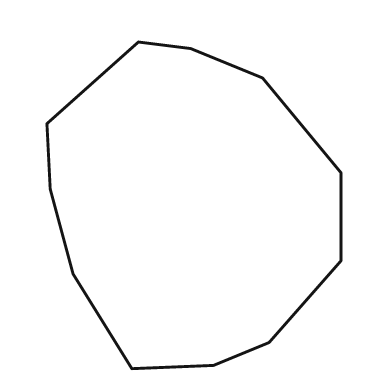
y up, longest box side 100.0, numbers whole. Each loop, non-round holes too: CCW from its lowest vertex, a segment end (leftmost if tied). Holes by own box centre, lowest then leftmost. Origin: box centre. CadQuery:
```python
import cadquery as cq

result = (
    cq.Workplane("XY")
    .moveTo(-19.0, -50.0)
    .lineTo(6.0, -49.0)
    .lineTo(23.0, -42.0)
    .lineTo(45.0, -17.0)
    .lineTo(45.0, 10.0)
    .lineTo(21.0, 39.0)
    .lineTo(-1.0, 48.0)
    .lineTo(-17.0, 50.0)
    .lineTo(-45.0, 25.0)
    .lineTo(-44.0, 5.0)
    .lineTo(-37.0, -21.0)
    .close()
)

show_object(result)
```